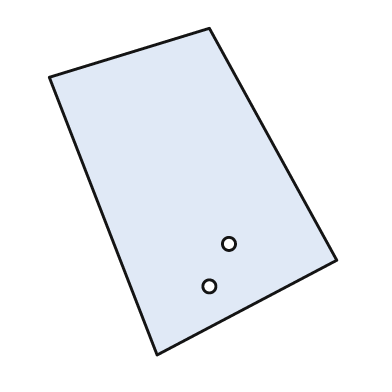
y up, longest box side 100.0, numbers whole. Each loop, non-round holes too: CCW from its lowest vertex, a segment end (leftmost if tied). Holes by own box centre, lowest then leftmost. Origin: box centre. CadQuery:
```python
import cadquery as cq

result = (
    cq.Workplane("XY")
    .moveTo(-11.0, -50.0)
    .lineTo(44.0, -21.0)
    .lineTo(5.0, 50.0)
    .lineTo(-44.0, 35.0)
    .close()
    .moveTo(5.0, -29.0)
    .circle(2.0)
    .moveTo(11.0, -16.0)
    .circle(2.0)
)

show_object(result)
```